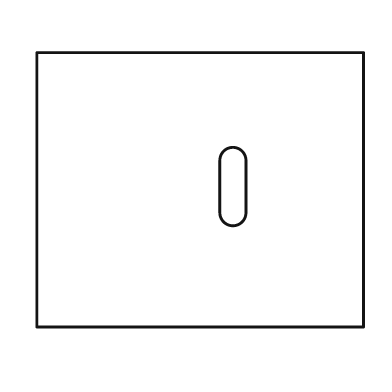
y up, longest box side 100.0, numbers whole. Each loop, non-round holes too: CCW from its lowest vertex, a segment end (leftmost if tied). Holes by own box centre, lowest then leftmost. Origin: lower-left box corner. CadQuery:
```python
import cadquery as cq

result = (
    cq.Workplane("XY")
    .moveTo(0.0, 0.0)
    .lineTo(100.0, 0.0)
    .lineTo(100.0, 84.0)
    .lineTo(0.0, 84.0)
    .close()
    .moveTo(56.0, 35.0)
    .threePointArc((60.0, 31.0), (64.0, 35.0))
    .lineTo(64.0, 51.0)
    .threePointArc((60.0, 55.0), (56.0, 51.0))
    .close()
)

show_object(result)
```